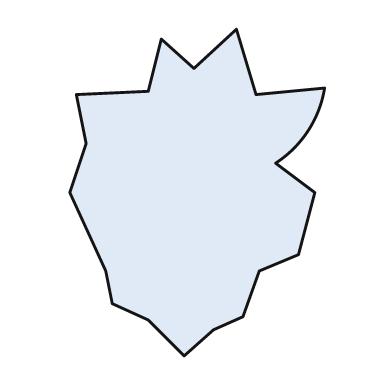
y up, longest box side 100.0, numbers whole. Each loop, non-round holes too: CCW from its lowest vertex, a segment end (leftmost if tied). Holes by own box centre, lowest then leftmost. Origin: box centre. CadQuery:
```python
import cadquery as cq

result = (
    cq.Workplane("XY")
    .moveTo(-4.0, -50.0)
    .lineTo(5.0, -42.0)
    .lineTo(14.0, -38.0)
    .lineTo(19.0, -24.0)
    .lineTo(31.0, -19.0)
    .lineTo(36.0, 0.0)
    .lineTo(24.0, 9.0)
    .threePointArc((34.0, 19.0), (39.0, 32.0))
    .lineTo(18.0, 30.0)
    .lineTo(12.0, 50.0)
    .lineTo(-1.0, 38.0)
    .lineTo(-11.0, 47.0)
    .lineTo(-15.0, 31.0)
    .lineTo(-37.0, 30.0)
    .lineTo(-34.0, 15.0)
    .lineTo(-39.0, 0.0)
    .lineTo(-28.0, -24.0)
    .lineTo(-26.0, -34.0)
    .lineTo(-15.0, -39.0)
    .close()
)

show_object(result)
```